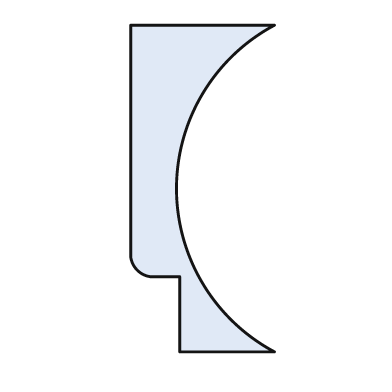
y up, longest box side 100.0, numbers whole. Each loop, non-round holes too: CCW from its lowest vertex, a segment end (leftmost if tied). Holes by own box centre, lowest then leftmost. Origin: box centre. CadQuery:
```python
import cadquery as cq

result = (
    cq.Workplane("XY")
    .moveTo(-7.0, -50.0)
    .lineTo(22.0, -50.0)
    .threePointArc((-8.0, 0.0), (22.0, 50.0))
    .lineTo(-22.0, 50.0)
    .lineTo(-22.0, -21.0)
    .threePointArc((-20.0, -25.0), (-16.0, -27.0))
    .lineTo(-7.0, -27.0)
    .close()
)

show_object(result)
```